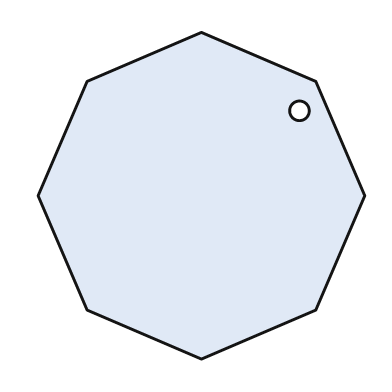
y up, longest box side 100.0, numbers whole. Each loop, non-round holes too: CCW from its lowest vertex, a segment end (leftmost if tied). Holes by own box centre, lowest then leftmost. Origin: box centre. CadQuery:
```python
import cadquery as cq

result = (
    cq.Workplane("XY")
    .moveTo(0.0, -50.0)
    .lineTo(35.0, -35.0)
    .lineTo(50.0, 0.0)
    .lineTo(35.0, 35.0)
    .lineTo(0.0, 50.0)
    .lineTo(-35.0, 35.0)
    .lineTo(-50.0, 0.0)
    .lineTo(-35.0, -35.0)
    .close()
    .moveTo(30.0, 26.0)
    .circle(3.0)
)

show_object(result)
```